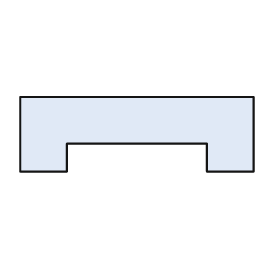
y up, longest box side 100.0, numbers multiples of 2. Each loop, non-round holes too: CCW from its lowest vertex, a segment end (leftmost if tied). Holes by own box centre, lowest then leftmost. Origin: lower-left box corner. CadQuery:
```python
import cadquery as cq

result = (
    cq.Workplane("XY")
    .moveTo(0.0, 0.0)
    .lineTo(20.0, 0.0)
    .lineTo(20.0, 12.0)
    .lineTo(80.0, 12.0)
    .lineTo(80.0, 0.0)
    .lineTo(100.0, 0.0)
    .lineTo(100.0, 32.0)
    .lineTo(0.0, 32.0)
    .close()
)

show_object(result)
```